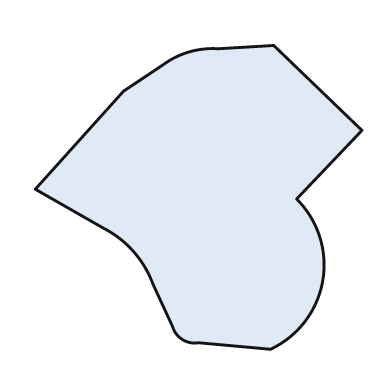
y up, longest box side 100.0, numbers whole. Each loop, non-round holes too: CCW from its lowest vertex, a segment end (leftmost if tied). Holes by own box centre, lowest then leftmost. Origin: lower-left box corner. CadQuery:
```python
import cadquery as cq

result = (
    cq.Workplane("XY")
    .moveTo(72.0, 0.0)
    .threePointArc((88.0, 21.0), (80.0, 46.0))
    .lineTo(100.0, 67.0)
    .lineTo(73.0, 93.0)
    .lineTo(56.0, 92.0)
    .threePointArc((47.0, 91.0), (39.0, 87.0))
    .lineTo(27.0, 79.0)
    .lineTo(0.0, 49.0)
    .lineTo(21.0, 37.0)
    .threePointArc((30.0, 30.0), (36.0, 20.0))
    .lineTo(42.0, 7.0)
    .threePointArc((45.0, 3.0), (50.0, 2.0))
    .close()
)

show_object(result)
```